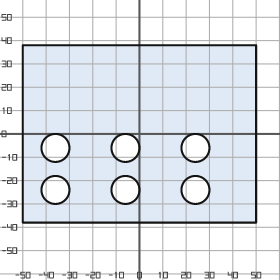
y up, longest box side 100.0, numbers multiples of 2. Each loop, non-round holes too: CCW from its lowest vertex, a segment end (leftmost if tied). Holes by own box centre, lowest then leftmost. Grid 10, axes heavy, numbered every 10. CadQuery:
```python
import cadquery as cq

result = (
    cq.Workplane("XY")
    .moveTo(-50.0, -38.0)
    .lineTo(50.0, -38.0)
    .lineTo(50.0, 38.0)
    .lineTo(-50.0, 38.0)
    .close()
    .moveTo(-36.0, -24.0)
    .circle(6.0)
    .moveTo(-6.0, -24.0)
    .circle(6.0)
    .moveTo(24.0, -24.0)
    .circle(6.0)
    .moveTo(-36.0, -6.0)
    .circle(6.0)
    .moveTo(-6.0, -6.0)
    .circle(6.0)
    .moveTo(24.0, -6.0)
    .circle(6.0)
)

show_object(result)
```